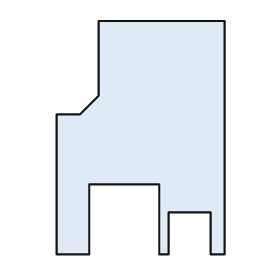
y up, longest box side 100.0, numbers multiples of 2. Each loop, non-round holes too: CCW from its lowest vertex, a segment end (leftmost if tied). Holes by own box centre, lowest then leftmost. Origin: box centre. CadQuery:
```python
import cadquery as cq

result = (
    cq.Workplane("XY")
    .moveTo(-36.0, -50.0)
    .lineTo(-22.0, -50.0)
    .lineTo(-22.0, -20.0)
    .lineTo(8.0, -20.0)
    .lineTo(8.0, -50.0)
    .lineTo(12.0, -50.0)
    .lineTo(12.0, -32.0)
    .lineTo(30.0, -32.0)
    .lineTo(30.0, -50.0)
    .lineTo(36.0, -50.0)
    .lineTo(36.0, 50.0)
    .lineTo(-18.0, 50.0)
    .lineTo(-18.0, 18.0)
    .lineTo(-26.0, 10.0)
    .lineTo(-36.0, 10.0)
    .close()
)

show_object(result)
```